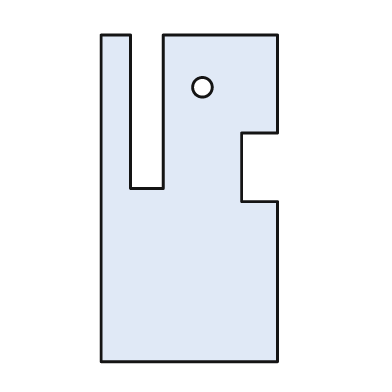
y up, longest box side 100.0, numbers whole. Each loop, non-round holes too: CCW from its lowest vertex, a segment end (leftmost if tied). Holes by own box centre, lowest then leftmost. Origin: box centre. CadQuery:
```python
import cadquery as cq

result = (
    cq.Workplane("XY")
    .moveTo(-27.0, -50.0)
    .lineTo(27.0, -50.0)
    .lineTo(27.0, -1.0)
    .lineTo(16.0, -1.0)
    .lineTo(16.0, 20.0)
    .lineTo(27.0, 20.0)
    .lineTo(27.0, 50.0)
    .lineTo(-8.0, 50.0)
    .lineTo(-8.0, 3.0)
    .lineTo(-18.0, 3.0)
    .lineTo(-18.0, 50.0)
    .lineTo(-27.0, 50.0)
    .close()
    .moveTo(4.0, 34.0)
    .circle(3.0)
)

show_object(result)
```